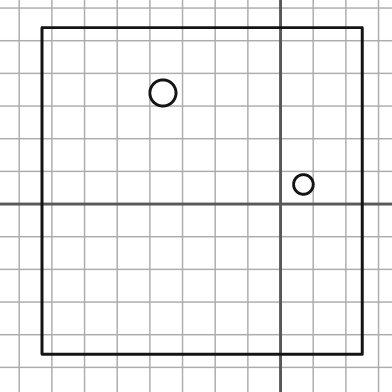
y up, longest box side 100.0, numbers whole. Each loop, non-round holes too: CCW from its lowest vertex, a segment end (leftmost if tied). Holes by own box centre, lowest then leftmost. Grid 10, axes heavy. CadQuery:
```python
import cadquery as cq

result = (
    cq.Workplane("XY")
    .moveTo(-73.0, -46.0)
    .lineTo(25.0, -46.0)
    .lineTo(25.0, 54.0)
    .lineTo(-73.0, 54.0)
    .close()
    .moveTo(7.0, 6.0)
    .circle(3.0)
    .moveTo(-36.0, 34.0)
    .circle(4.0)
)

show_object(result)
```